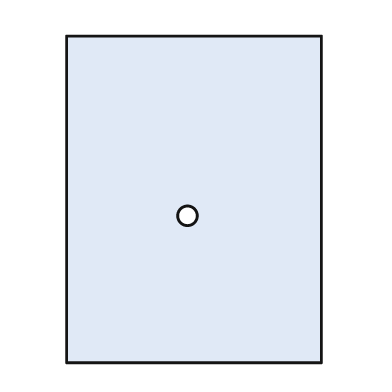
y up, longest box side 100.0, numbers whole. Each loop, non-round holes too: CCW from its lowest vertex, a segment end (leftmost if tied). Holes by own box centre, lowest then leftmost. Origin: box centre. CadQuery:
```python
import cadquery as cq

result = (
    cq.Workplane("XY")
    .moveTo(-39.0, -50.0)
    .lineTo(39.0, -50.0)
    .lineTo(39.0, 50.0)
    .lineTo(-39.0, 50.0)
    .close()
    .moveTo(-2.0, -5.0)
    .circle(3.0)
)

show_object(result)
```